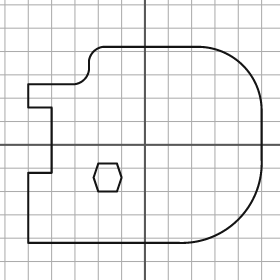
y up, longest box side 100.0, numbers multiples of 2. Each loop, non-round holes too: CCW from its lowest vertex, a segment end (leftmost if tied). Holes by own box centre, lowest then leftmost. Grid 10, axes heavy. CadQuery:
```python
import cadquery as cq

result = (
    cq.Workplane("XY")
    .moveTo(-50.0, -42.0)
    .lineTo(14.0, -42.0)
    .threePointArc((40.0, -32.0), (50.0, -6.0))
    .lineTo(50.0, 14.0)
    .threePointArc((42.0, 34.0), (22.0, 42.0))
    .lineTo(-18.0, 42.0)
    .threePointArc((-22.0, 40.0), (-24.0, 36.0))
    .lineTo(-24.0, 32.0)
    .threePointArc((-26.0, 28.0), (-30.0, 26.0))
    .lineTo(-50.0, 26.0)
    .lineTo(-50.0, 16.0)
    .lineTo(-40.0, 16.0)
    .lineTo(-40.0, -12.0)
    .lineTo(-50.0, -12.0)
    .close()
    .moveTo(-20.0, -20.0)
    .lineTo(-12.0, -20.0)
    .lineTo(-10.0, -14.0)
    .lineTo(-12.0, -8.0)
    .lineTo(-20.0, -8.0)
    .lineTo(-22.0, -14.0)
    .close()
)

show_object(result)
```